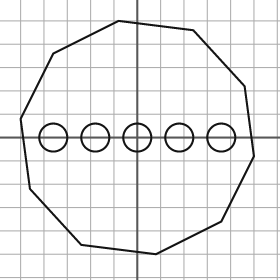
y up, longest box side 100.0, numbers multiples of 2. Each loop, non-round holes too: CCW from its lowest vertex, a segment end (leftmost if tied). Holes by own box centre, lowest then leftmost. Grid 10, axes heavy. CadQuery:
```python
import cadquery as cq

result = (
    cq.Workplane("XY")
    .moveTo(8.0, -50.0)
    .lineTo(36.0, -36.0)
    .lineTo(50.0, -8.0)
    .lineTo(46.0, 22.0)
    .lineTo(24.0, 46.0)
    .lineTo(-8.0, 50.0)
    .lineTo(-36.0, 36.0)
    .lineTo(-50.0, 8.0)
    .lineTo(-46.0, -22.0)
    .lineTo(-24.0, -46.0)
    .close()
    .moveTo(-36.0, 0.0)
    .circle(6.0)
    .moveTo(-18.0, 0.0)
    .circle(6.0)
    .moveTo(0.0, 0.0)
    .circle(6.0)
    .moveTo(18.0, 0.0)
    .circle(6.0)
    .moveTo(36.0, 0.0)
    .circle(6.0)
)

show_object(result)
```